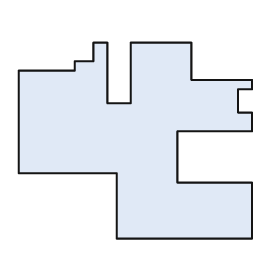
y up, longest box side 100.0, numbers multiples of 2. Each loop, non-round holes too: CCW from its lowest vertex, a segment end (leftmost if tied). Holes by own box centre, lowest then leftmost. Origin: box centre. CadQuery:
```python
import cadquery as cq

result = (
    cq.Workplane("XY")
    .moveTo(-8.0, -42.0)
    .lineTo(50.0, -42.0)
    .lineTo(50.0, -18.0)
    .lineTo(18.0, -18.0)
    .lineTo(18.0, 4.0)
    .lineTo(50.0, 4.0)
    .lineTo(50.0, 12.0)
    .lineTo(44.0, 12.0)
    .lineTo(44.0, 22.0)
    .lineTo(50.0, 22.0)
    .lineTo(50.0, 26.0)
    .lineTo(24.0, 26.0)
    .lineTo(24.0, 42.0)
    .lineTo(-2.0, 42.0)
    .lineTo(-2.0, 16.0)
    .lineTo(-12.0, 16.0)
    .lineTo(-12.0, 42.0)
    .lineTo(-18.0, 42.0)
    .lineTo(-18.0, 34.0)
    .lineTo(-26.0, 34.0)
    .lineTo(-26.0, 30.0)
    .lineTo(-50.0, 30.0)
    .lineTo(-50.0, -14.0)
    .lineTo(-8.0, -14.0)
    .close()
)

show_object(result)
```